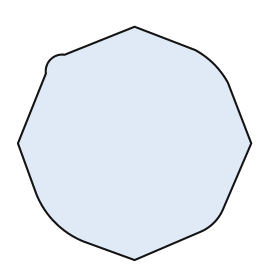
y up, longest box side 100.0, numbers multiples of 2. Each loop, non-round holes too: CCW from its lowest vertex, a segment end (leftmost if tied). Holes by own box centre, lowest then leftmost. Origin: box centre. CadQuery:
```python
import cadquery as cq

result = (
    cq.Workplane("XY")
    .moveTo(0.0, -50.0)
    .lineTo(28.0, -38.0)
    .threePointArc((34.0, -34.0), (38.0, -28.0))
    .lineTo(50.0, 0.0)
    .lineTo(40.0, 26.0)
    .threePointArc((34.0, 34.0), (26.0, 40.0))
    .lineTo(0.0, 50.0)
    .lineTo(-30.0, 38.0)
    .threePointArc((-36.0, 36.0), (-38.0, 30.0))
    .lineTo(-50.0, 0.0)
    .lineTo(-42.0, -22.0)
    .threePointArc((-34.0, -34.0), (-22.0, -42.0))
    .close()
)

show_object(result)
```